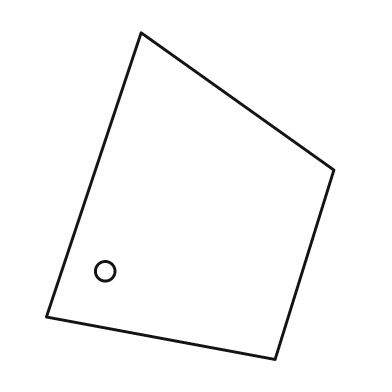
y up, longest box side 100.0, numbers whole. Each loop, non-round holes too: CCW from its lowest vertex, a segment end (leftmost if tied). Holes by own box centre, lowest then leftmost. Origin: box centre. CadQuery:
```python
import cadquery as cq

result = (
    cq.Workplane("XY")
    .moveTo(26.0, -50.0)
    .lineTo(44.0, 8.0)
    .lineTo(-15.0, 50.0)
    .lineTo(-44.0, -37.0)
    .close()
    .moveTo(-26.0, -23.0)
    .circle(3.0)
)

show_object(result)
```